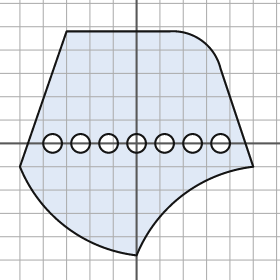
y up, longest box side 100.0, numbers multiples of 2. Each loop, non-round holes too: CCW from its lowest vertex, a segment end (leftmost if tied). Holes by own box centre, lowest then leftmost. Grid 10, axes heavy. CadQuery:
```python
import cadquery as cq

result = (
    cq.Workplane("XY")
    .moveTo(0.0, -48.0)
    .threePointArc((20.0, -22.0), (50.0, -10.0))
    .lineTo(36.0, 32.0)
    .threePointArc((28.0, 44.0), (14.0, 48.0))
    .lineTo(-30.0, 48.0)
    .lineTo(-50.0, -10.0)
    .threePointArc((-30.0, -36.0), (0.0, -48.0))
    .close()
    .moveTo(-36.0, 0.0)
    .circle(4.0)
    .moveTo(-24.0, 0.0)
    .circle(4.0)
    .moveTo(-12.0, 0.0)
    .circle(4.0)
    .moveTo(0.0, 0.0)
    .circle(4.0)
    .moveTo(12.0, 0.0)
    .circle(4.0)
    .moveTo(24.0, 0.0)
    .circle(4.0)
    .moveTo(36.0, 0.0)
    .circle(4.0)
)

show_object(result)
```